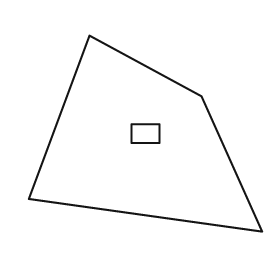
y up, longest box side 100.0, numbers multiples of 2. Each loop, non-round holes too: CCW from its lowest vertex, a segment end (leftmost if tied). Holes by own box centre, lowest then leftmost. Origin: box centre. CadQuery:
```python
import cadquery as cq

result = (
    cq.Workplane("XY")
    .moveTo(50.0, -42.0)
    .lineTo(24.0, 16.0)
    .lineTo(-24.0, 42.0)
    .lineTo(-50.0, -28.0)
    .close()
    .moveTo(-6.0, -4.0)
    .lineTo(6.0, -4.0)
    .lineTo(6.0, 4.0)
    .lineTo(-6.0, 4.0)
    .close()
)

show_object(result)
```